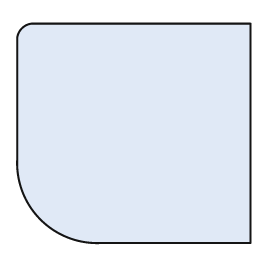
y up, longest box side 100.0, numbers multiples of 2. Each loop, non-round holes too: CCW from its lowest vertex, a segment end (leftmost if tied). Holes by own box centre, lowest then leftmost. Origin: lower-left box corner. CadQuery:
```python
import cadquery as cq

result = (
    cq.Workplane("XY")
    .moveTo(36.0, 0.0)
    .lineTo(100.0, 0.0)
    .lineTo(100.0, 94.0)
    .lineTo(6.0, 94.0)
    .threePointArc((2.0, 92.0), (0.0, 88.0))
    .lineTo(0.0, 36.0)
    .threePointArc((10.0, 10.0), (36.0, 0.0))
    .close()
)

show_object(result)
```